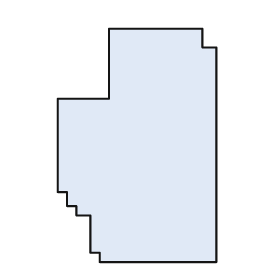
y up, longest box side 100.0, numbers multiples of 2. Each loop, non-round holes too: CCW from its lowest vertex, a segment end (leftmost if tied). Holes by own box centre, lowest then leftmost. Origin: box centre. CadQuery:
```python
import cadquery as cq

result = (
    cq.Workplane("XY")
    .moveTo(-16.0, -50.0)
    .lineTo(34.0, -50.0)
    .lineTo(34.0, 42.0)
    .lineTo(28.0, 42.0)
    .lineTo(28.0, 50.0)
    .lineTo(-12.0, 50.0)
    .lineTo(-12.0, 20.0)
    .lineTo(-34.0, 20.0)
    .lineTo(-34.0, -20.0)
    .lineTo(-30.0, -20.0)
    .lineTo(-30.0, -26.0)
    .lineTo(-26.0, -26.0)
    .lineTo(-26.0, -30.0)
    .lineTo(-20.0, -30.0)
    .lineTo(-20.0, -46.0)
    .lineTo(-16.0, -46.0)
    .close()
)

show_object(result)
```